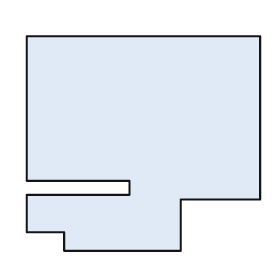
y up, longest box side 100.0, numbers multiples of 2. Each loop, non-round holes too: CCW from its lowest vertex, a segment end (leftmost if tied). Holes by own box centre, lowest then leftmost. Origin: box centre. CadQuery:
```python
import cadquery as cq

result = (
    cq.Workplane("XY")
    .moveTo(-34.0, -46.0)
    .lineTo(16.0, -46.0)
    .lineTo(16.0, -24.0)
    .lineTo(50.0, -24.0)
    .lineTo(50.0, 46.0)
    .lineTo(-50.0, 46.0)
    .lineTo(-50.0, -16.0)
    .lineTo(-6.0, -16.0)
    .lineTo(-6.0, -22.0)
    .lineTo(-50.0, -22.0)
    .lineTo(-50.0, -38.0)
    .lineTo(-34.0, -38.0)
    .close()
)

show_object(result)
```